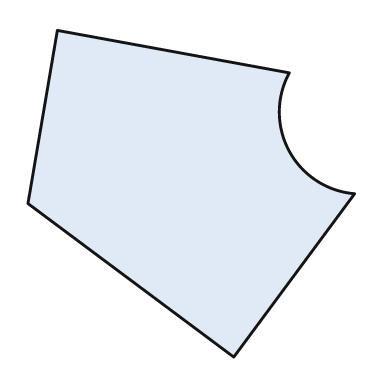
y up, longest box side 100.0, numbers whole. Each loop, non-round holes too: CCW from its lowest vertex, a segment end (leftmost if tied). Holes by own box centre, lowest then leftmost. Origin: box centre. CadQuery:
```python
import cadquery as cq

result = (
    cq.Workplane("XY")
    .moveTo(13.0, -50.0)
    .lineTo(50.0, 0.0)
    .threePointArc((30.0, 13.0), (30.0, 37.0))
    .lineTo(-41.0, 50.0)
    .lineTo(-50.0, -3.0)
    .close()
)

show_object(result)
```